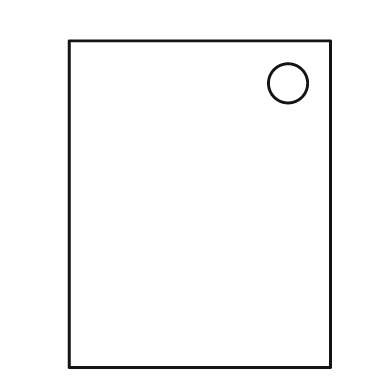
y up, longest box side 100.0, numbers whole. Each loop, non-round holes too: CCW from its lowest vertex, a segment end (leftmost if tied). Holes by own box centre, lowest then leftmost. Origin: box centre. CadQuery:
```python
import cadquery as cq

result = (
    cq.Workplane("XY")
    .moveTo(-40.0, -50.0)
    .lineTo(40.0, -50.0)
    .lineTo(40.0, 50.0)
    .lineTo(-40.0, 50.0)
    .close()
    .moveTo(27.0, 37.0)
    .circle(6.0)
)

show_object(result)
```